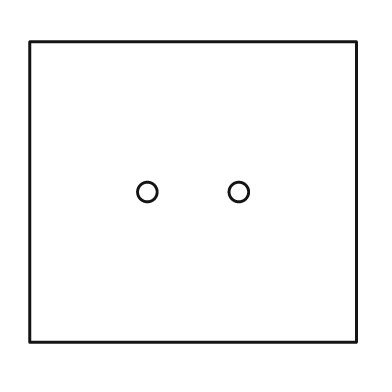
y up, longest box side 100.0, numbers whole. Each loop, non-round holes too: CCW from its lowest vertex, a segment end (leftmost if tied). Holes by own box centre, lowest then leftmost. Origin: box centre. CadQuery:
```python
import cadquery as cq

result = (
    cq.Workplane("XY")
    .moveTo(-50.0, -46.0)
    .lineTo(50.0, -46.0)
    .lineTo(50.0, 46.0)
    .lineTo(-50.0, 46.0)
    .close()
    .moveTo(-14.0, 0.0)
    .circle(3.0)
    .moveTo(14.0, 0.0)
    .circle(3.0)
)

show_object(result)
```